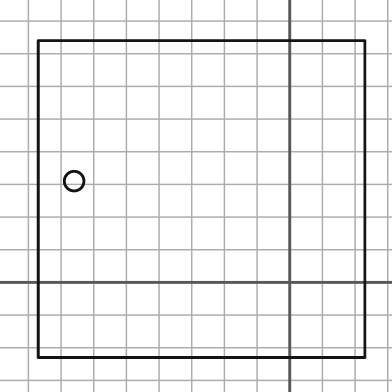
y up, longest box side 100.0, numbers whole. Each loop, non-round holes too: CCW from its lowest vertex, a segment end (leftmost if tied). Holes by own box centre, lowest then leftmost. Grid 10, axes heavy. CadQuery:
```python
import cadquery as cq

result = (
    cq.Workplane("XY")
    .moveTo(-77.0, -23.0)
    .lineTo(23.0, -23.0)
    .lineTo(23.0, 74.0)
    .lineTo(-77.0, 74.0)
    .close()
    .moveTo(-66.0, 31.0)
    .circle(3.0)
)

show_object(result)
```